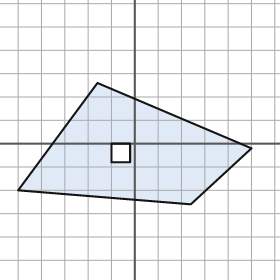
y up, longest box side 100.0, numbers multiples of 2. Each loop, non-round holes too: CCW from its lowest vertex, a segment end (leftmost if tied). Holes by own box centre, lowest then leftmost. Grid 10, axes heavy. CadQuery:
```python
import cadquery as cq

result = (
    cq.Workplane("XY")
    .moveTo(24.0, -26.0)
    .lineTo(50.0, -2.0)
    .lineTo(-16.0, 26.0)
    .lineTo(-50.0, -20.0)
    .close()
    .moveTo(-10.0, -8.0)
    .lineTo(-2.0, -8.0)
    .lineTo(-2.0, 0.0)
    .lineTo(-10.0, 0.0)
    .close()
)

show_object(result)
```